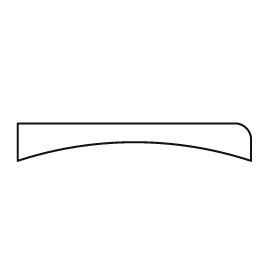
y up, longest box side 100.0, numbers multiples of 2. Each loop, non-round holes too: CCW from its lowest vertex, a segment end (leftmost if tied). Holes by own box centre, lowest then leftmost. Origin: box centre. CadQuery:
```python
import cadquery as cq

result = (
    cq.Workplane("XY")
    .moveTo(-50.0, -8.0)
    .threePointArc((0.0, 0.0), (50.0, -8.0))
    .lineTo(50.0, 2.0)
    .threePointArc((48.0, 6.0), (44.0, 8.0))
    .lineTo(-50.0, 8.0)
    .close()
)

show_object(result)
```